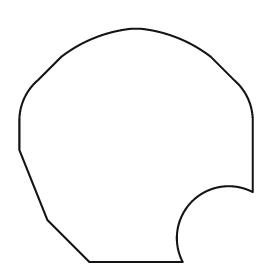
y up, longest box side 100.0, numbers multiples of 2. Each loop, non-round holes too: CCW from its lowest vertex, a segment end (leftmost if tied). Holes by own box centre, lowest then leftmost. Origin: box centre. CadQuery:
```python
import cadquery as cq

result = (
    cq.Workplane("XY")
    .moveTo(-20.0, -50.0)
    .lineTo(20.0, -50.0)
    .threePointArc((24.0, -24.0), (50.0, -20.0))
    .lineTo(50.0, 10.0)
    .threePointArc((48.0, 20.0), (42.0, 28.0))
    .lineTo(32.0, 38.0)
    .threePointArc((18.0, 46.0), (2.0, 50.0))
    .lineTo(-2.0, 50.0)
    .threePointArc((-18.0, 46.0), (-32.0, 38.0))
    .lineTo(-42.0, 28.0)
    .threePointArc((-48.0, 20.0), (-50.0, 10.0))
    .lineTo(-50.0, -2.0)
    .lineTo(-38.0, -32.0)
    .close()
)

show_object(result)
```